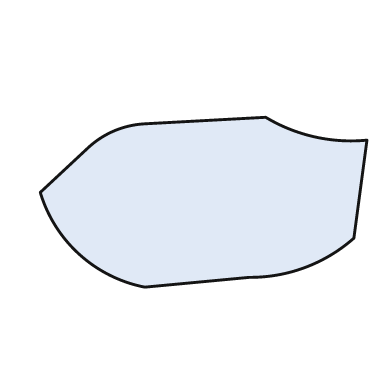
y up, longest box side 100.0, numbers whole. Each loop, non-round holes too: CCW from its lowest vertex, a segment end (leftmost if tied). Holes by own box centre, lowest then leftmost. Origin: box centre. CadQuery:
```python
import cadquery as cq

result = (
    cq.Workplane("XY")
    .moveTo(-18.0, -26.0)
    .lineTo(14.0, -23.0)
    .threePointArc((31.0, -20.0), (46.0, -11.0))
    .lineTo(50.0, 19.0)
    .threePointArc((34.0, 20.0), (19.0, 26.0))
    .lineTo(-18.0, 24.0)
    .threePointArc((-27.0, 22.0), (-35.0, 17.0))
    .lineTo(-50.0, 3.0)
    .threePointArc((-38.0, -16.0), (-18.0, -26.0))
    .close()
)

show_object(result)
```